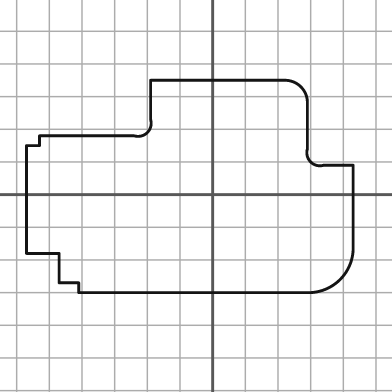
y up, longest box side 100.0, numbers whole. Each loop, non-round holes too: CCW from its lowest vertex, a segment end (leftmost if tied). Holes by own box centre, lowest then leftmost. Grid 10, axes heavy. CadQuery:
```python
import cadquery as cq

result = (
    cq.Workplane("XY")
    .moveTo(-41.0, -30.0)
    .lineTo(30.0, -30.0)
    .threePointArc((39.0, -26.0), (43.0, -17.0))
    .lineTo(43.0, 9.0)
    .lineTo(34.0, 9.0)
    .threePointArc((30.0, 10.0), (29.0, 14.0))
    .lineTo(29.0, 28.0)
    .threePointArc((27.0, 33.0), (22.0, 35.0))
    .lineTo(-19.0, 35.0)
    .lineTo(-19.0, 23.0)
    .threePointArc((-20.0, 19.0), (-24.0, 18.0))
    .lineTo(-53.0, 18.0)
    .lineTo(-53.0, 15.0)
    .lineTo(-57.0, 15.0)
    .lineTo(-57.0, -18.0)
    .lineTo(-47.0, -18.0)
    .lineTo(-47.0, -27.0)
    .lineTo(-41.0, -27.0)
    .close()
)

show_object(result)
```